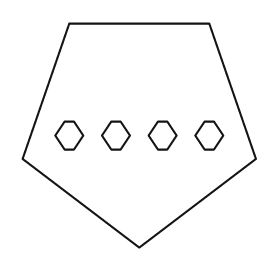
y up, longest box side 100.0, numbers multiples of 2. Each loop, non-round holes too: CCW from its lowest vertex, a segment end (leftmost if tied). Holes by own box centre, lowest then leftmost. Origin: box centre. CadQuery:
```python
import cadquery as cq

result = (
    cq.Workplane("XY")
    .moveTo(0.0, -48.0)
    .lineTo(50.0, -10.0)
    .lineTo(30.0, 48.0)
    .lineTo(-30.0, 48.0)
    .lineTo(-50.0, -10.0)
    .close()
    .moveTo(-32.0, -6.0)
    .lineTo(-28.0, -6.0)
    .lineTo(-24.0, 0.0)
    .lineTo(-28.0, 6.0)
    .lineTo(-32.0, 6.0)
    .lineTo(-36.0, 0.0)
    .close()
    .moveTo(-12.0, -6.0)
    .lineTo(-8.0, -6.0)
    .lineTo(-4.0, 0.0)
    .lineTo(-8.0, 6.0)
    .lineTo(-12.0, 6.0)
    .lineTo(-16.0, 0.0)
    .close()
    .moveTo(8.0, -6.0)
    .lineTo(12.0, -6.0)
    .lineTo(16.0, 0.0)
    .lineTo(12.0, 6.0)
    .lineTo(8.0, 6.0)
    .lineTo(4.0, 0.0)
    .close()
    .moveTo(28.0, -6.0)
    .lineTo(32.0, -6.0)
    .lineTo(36.0, 0.0)
    .lineTo(32.0, 6.0)
    .lineTo(28.0, 6.0)
    .lineTo(24.0, 0.0)
    .close()
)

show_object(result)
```